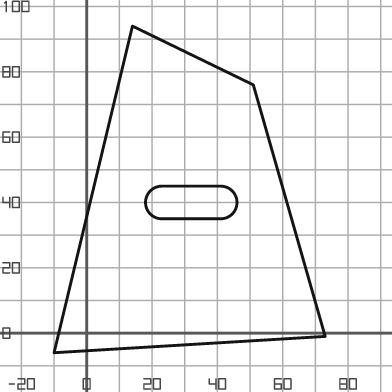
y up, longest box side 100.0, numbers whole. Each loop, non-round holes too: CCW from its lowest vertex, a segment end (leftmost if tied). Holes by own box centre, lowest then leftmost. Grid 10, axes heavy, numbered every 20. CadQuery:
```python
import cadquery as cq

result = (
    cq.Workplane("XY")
    .moveTo(-10.0, -6.0)
    .lineTo(73.0, -1.0)
    .lineTo(51.0, 76.0)
    .lineTo(14.0, 94.0)
    .close()
    .moveTo(23.0, 35.0)
    .lineTo(41.0, 35.0)
    .threePointArc((46.0, 40.0), (41.0, 45.0))
    .lineTo(23.0, 45.0)
    .threePointArc((18.0, 40.0), (23.0, 35.0))
    .close()
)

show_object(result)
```